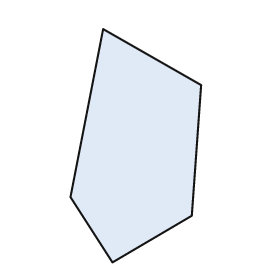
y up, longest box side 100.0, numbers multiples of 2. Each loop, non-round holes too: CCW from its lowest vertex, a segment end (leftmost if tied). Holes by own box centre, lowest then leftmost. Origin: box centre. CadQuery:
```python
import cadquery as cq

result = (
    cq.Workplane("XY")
    .moveTo(-10.0, -50.0)
    .lineTo(24.0, -30.0)
    .lineTo(28.0, 26.0)
    .lineTo(-14.0, 50.0)
    .lineTo(-28.0, -22.0)
    .close()
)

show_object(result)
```